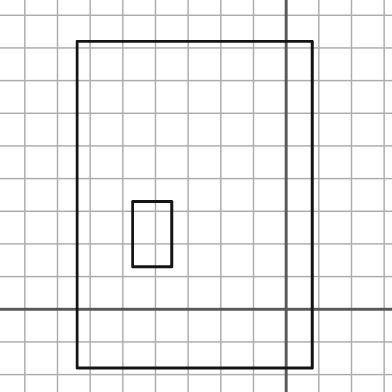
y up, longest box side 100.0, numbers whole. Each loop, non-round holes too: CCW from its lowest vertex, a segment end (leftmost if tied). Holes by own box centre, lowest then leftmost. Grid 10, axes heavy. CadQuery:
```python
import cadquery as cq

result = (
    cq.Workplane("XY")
    .moveTo(-64.0, -18.0)
    .lineTo(8.0, -18.0)
    .lineTo(8.0, 82.0)
    .lineTo(-64.0, 82.0)
    .close()
    .moveTo(-47.0, 13.0)
    .lineTo(-35.0, 13.0)
    .lineTo(-35.0, 33.0)
    .lineTo(-47.0, 33.0)
    .close()
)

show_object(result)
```